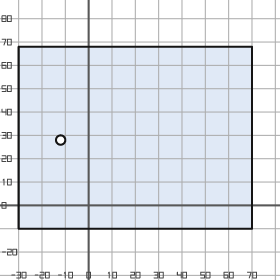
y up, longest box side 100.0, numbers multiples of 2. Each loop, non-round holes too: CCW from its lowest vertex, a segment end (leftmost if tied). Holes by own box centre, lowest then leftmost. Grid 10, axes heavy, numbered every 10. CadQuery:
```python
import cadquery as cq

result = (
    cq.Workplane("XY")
    .moveTo(-30.0, -10.0)
    .lineTo(70.0, -10.0)
    .lineTo(70.0, 68.0)
    .lineTo(-30.0, 68.0)
    .close()
    .moveTo(-12.0, 28.0)
    .circle(2.0)
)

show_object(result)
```